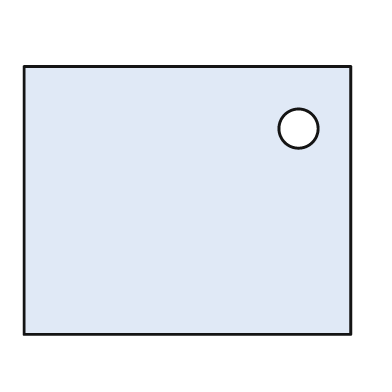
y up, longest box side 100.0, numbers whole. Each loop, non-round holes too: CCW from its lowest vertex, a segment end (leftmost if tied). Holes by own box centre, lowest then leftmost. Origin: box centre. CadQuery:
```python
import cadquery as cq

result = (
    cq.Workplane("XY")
    .moveTo(-50.0, -41.0)
    .lineTo(50.0, -41.0)
    .lineTo(50.0, 41.0)
    .lineTo(-50.0, 41.0)
    .close()
    .moveTo(34.0, 22.0)
    .circle(6.0)
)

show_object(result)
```